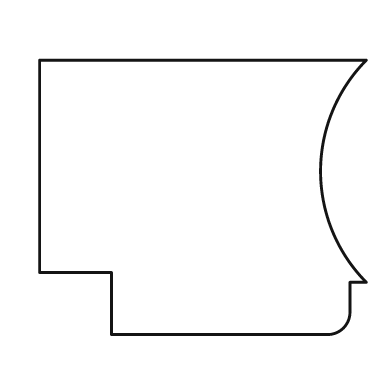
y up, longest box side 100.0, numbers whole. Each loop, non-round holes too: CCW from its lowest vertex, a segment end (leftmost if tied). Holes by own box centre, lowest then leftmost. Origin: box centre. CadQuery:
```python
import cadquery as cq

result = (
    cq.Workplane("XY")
    .moveTo(-28.0, -42.0)
    .lineTo(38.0, -42.0)
    .threePointArc((43.0, -40.0), (45.0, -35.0))
    .lineTo(45.0, -26.0)
    .lineTo(50.0, -26.0)
    .threePointArc((36.0, 8.0), (50.0, 42.0))
    .lineTo(-50.0, 42.0)
    .lineTo(-50.0, -23.0)
    .lineTo(-28.0, -23.0)
    .close()
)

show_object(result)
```